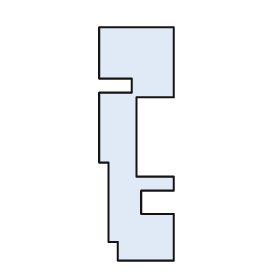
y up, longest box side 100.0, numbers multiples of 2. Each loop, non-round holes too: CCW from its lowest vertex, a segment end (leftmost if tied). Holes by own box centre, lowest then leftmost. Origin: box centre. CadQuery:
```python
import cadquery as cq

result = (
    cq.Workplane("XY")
    .moveTo(-8.0, -50.0)
    .lineTo(16.0, -50.0)
    .lineTo(16.0, -30.0)
    .lineTo(2.0, -30.0)
    .lineTo(2.0, -20.0)
    .lineTo(16.0, -20.0)
    .lineTo(16.0, -14.0)
    .lineTo(0.0, -14.0)
    .lineTo(0.0, 20.0)
    .lineTo(16.0, 20.0)
    .lineTo(16.0, 50.0)
    .lineTo(-16.0, 50.0)
    .lineTo(-16.0, 28.0)
    .lineTo(-2.0, 28.0)
    .lineTo(-2.0, 22.0)
    .lineTo(-16.0, 22.0)
    .lineTo(-16.0, -8.0)
    .lineTo(-12.0, -8.0)
    .lineTo(-12.0, -42.0)
    .lineTo(-8.0, -42.0)
    .close()
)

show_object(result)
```